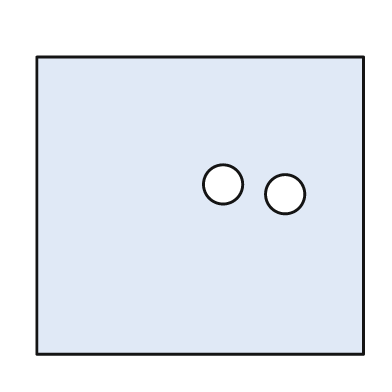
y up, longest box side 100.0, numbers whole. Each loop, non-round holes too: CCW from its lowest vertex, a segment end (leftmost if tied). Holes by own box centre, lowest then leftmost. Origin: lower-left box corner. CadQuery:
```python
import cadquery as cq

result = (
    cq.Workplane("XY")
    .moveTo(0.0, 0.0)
    .lineTo(100.0, 0.0)
    .lineTo(100.0, 91.0)
    .lineTo(0.0, 91.0)
    .close()
    .moveTo(76.0, 49.0)
    .circle(6.0)
    .moveTo(57.0, 52.0)
    .circle(6.0)
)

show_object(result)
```